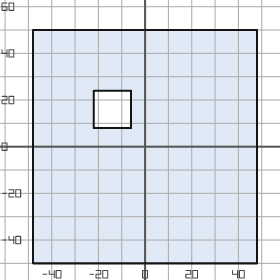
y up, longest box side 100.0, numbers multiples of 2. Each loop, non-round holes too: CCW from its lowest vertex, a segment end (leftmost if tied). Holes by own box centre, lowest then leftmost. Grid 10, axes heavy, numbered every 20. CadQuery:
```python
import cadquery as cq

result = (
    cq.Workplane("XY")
    .moveTo(-48.0, -50.0)
    .lineTo(48.0, -50.0)
    .lineTo(48.0, 50.0)
    .lineTo(-48.0, 50.0)
    .close()
    .moveTo(-22.0, 8.0)
    .lineTo(-6.0, 8.0)
    .lineTo(-6.0, 24.0)
    .lineTo(-22.0, 24.0)
    .close()
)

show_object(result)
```